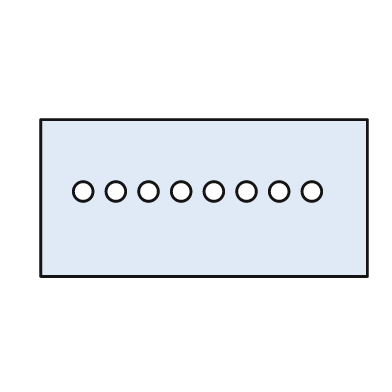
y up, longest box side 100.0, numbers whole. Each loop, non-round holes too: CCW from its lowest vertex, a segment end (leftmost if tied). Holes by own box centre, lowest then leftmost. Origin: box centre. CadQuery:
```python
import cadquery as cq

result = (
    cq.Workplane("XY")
    .moveTo(-50.0, -24.0)
    .lineTo(50.0, -24.0)
    .lineTo(50.0, 24.0)
    .lineTo(-50.0, 24.0)
    .close()
    .moveTo(-37.0, 2.0)
    .circle(3.0)
    .moveTo(-27.0, 2.0)
    .circle(3.0)
    .moveTo(-17.0, 2.0)
    .circle(3.0)
    .moveTo(-7.0, 2.0)
    .circle(3.0)
    .moveTo(3.0, 2.0)
    .circle(3.0)
    .moveTo(13.0, 2.0)
    .circle(3.0)
    .moveTo(23.0, 2.0)
    .circle(3.0)
    .moveTo(33.0, 2.0)
    .circle(3.0)
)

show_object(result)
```